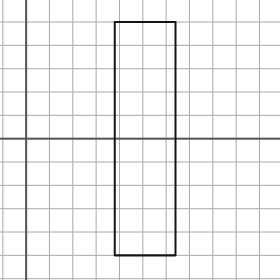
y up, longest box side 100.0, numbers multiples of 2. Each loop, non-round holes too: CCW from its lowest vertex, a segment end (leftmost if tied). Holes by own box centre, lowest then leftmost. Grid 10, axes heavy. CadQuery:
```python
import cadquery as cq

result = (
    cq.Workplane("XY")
    .moveTo(38.0, -50.0)
    .lineTo(64.0, -50.0)
    .lineTo(64.0, 50.0)
    .lineTo(38.0, 50.0)
    .close()
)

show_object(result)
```